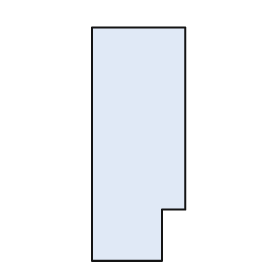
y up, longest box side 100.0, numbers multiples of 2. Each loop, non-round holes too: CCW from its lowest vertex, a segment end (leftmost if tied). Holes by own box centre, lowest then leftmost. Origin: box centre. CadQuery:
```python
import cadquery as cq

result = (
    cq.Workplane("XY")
    .moveTo(-20.0, -50.0)
    .lineTo(10.0, -50.0)
    .lineTo(10.0, -28.0)
    .lineTo(20.0, -28.0)
    .lineTo(20.0, 50.0)
    .lineTo(-20.0, 50.0)
    .close()
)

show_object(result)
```